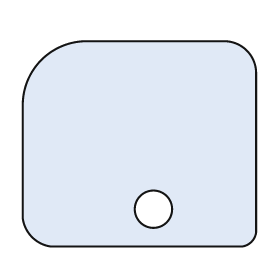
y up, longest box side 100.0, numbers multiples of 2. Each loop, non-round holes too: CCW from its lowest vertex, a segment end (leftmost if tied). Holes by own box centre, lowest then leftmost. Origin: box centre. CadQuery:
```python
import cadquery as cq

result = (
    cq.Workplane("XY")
    .moveTo(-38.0, -44.0)
    .lineTo(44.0, -44.0)
    .threePointArc((48.0, -42.0), (50.0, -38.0))
    .lineTo(50.0, 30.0)
    .threePointArc((46.0, 40.0), (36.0, 44.0))
    .lineTo(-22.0, 44.0)
    .threePointArc((-42.0, 36.0), (-50.0, 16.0))
    .lineTo(-50.0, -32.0)
    .threePointArc((-46.0, -40.0), (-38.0, -44.0))
    .close()
    .moveTo(6.0, -28.0)
    .circle(8.0)
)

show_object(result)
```